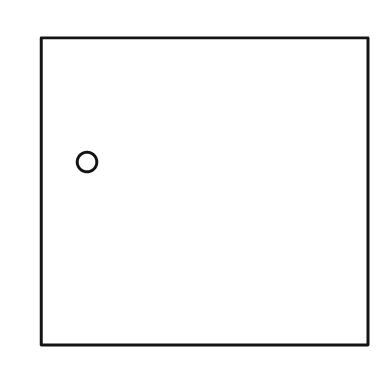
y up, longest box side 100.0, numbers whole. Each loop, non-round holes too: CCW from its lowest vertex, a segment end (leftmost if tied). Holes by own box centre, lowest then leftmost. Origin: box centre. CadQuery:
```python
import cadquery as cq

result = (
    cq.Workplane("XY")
    .moveTo(-50.0, -47.0)
    .lineTo(50.0, -47.0)
    .lineTo(50.0, 47.0)
    .lineTo(-50.0, 47.0)
    .close()
    .moveTo(-36.0, 9.0)
    .circle(3.0)
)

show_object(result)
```